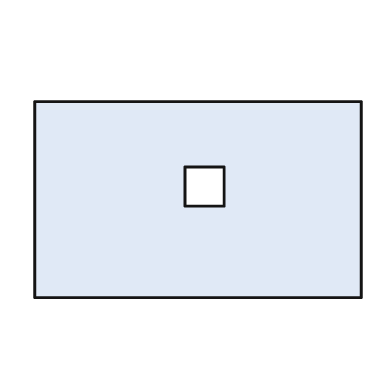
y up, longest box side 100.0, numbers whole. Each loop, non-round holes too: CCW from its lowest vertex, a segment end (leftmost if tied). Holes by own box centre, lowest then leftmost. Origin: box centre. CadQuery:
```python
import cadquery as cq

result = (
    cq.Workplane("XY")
    .moveTo(-50.0, -30.0)
    .lineTo(50.0, -30.0)
    .lineTo(50.0, 30.0)
    .lineTo(-50.0, 30.0)
    .close()
    .moveTo(-4.0, -2.0)
    .lineTo(8.0, -2.0)
    .lineTo(8.0, 10.0)
    .lineTo(-4.0, 10.0)
    .close()
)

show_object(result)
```